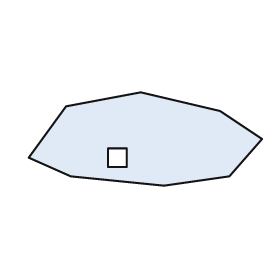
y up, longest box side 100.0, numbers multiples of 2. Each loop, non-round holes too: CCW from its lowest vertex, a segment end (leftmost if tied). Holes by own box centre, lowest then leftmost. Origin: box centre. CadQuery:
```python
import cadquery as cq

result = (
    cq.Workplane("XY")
    .moveTo(8.0, -20.0)
    .lineTo(36.0, -16.0)
    .lineTo(50.0, 0.0)
    .lineTo(32.0, 12.0)
    .lineTo(-2.0, 20.0)
    .lineTo(-34.0, 14.0)
    .lineTo(-50.0, -8.0)
    .lineTo(-32.0, -16.0)
    .close()
    .moveTo(-16.0, -12.0)
    .lineTo(-8.0, -12.0)
    .lineTo(-8.0, -4.0)
    .lineTo(-16.0, -4.0)
    .close()
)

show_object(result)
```